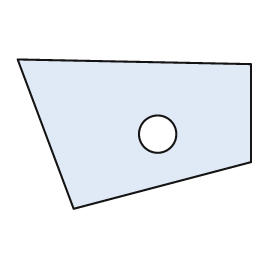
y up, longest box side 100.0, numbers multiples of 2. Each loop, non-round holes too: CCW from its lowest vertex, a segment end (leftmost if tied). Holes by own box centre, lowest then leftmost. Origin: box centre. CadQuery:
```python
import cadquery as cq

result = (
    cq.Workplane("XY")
    .moveTo(-26.0, -32.0)
    .lineTo(50.0, -12.0)
    .lineTo(50.0, 30.0)
    .lineTo(-50.0, 32.0)
    .close()
    .moveTo(10.0, 0.0)
    .circle(8.0)
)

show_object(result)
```